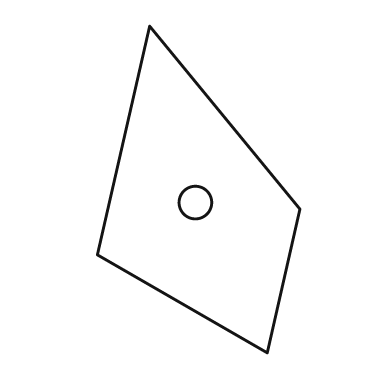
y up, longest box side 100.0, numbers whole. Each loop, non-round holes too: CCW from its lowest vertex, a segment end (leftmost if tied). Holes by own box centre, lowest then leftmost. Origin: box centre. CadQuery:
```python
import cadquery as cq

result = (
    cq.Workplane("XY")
    .moveTo(21.0, -50.0)
    .lineTo(31.0, -6.0)
    .lineTo(-15.0, 50.0)
    .lineTo(-31.0, -20.0)
    .close()
    .moveTo(-1.0, -4.0)
    .circle(5.0)
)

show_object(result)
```